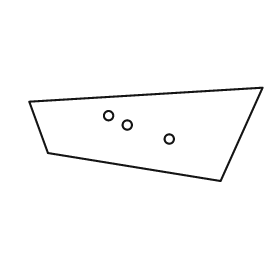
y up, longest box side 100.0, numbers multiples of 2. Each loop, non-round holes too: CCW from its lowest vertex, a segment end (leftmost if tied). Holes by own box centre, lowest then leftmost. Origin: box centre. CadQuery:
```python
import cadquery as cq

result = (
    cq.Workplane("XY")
    .moveTo(32.0, -20.0)
    .lineTo(50.0, 20.0)
    .lineTo(-50.0, 14.0)
    .lineTo(-42.0, -8.0)
    .close()
    .moveTo(10.0, -2.0)
    .circle(2.0)
    .moveTo(-8.0, 4.0)
    .circle(2.0)
    .moveTo(-16.0, 8.0)
    .circle(2.0)
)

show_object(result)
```